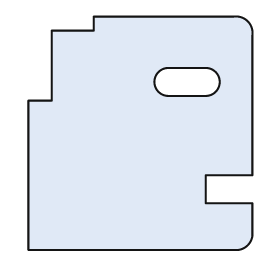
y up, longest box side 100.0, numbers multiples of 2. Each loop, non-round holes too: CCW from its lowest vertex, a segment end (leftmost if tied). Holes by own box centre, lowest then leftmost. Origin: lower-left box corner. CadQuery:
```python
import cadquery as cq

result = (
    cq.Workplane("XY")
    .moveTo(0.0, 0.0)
    .lineTo(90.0, 0.0)
    .threePointArc((94.0, 2.0), (96.0, 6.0))
    .lineTo(96.0, 20.0)
    .lineTo(76.0, 20.0)
    .lineTo(76.0, 32.0)
    .lineTo(96.0, 32.0)
    .lineTo(96.0, 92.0)
    .threePointArc((94.0, 98.0), (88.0, 100.0))
    .lineTo(28.0, 100.0)
    .lineTo(28.0, 94.0)
    .lineTo(10.0, 94.0)
    .lineTo(10.0, 64.0)
    .lineTo(0.0, 64.0)
    .close()
    .moveTo(60.0, 66.0)
    .lineTo(76.0, 66.0)
    .threePointArc((82.0, 72.0), (76.0, 78.0))
    .lineTo(60.0, 78.0)
    .threePointArc((54.0, 72.0), (60.0, 66.0))
    .close()
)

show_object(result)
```